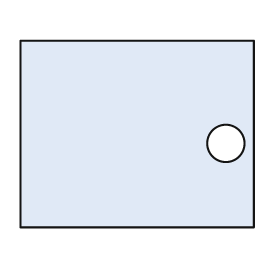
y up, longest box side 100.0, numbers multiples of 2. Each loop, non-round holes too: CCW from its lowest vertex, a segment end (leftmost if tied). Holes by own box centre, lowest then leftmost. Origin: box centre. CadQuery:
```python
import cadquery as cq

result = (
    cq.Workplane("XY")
    .moveTo(-50.0, -40.0)
    .lineTo(50.0, -40.0)
    .lineTo(50.0, 40.0)
    .lineTo(-50.0, 40.0)
    .close()
    .moveTo(38.0, -4.0)
    .circle(8.0)
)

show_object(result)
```